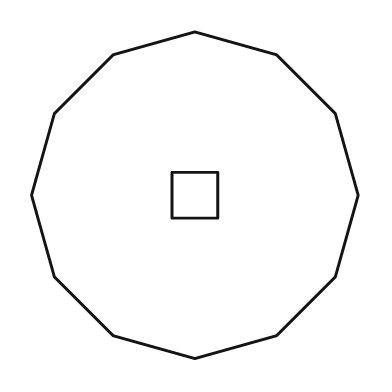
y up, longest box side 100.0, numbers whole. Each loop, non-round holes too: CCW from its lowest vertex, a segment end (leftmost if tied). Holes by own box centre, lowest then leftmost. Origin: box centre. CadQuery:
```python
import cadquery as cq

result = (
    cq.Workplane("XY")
    .moveTo(0.0, -50.0)
    .lineTo(25.0, -43.0)
    .lineTo(43.0, -25.0)
    .lineTo(50.0, 0.0)
    .lineTo(43.0, 25.0)
    .lineTo(25.0, 43.0)
    .lineTo(0.0, 50.0)
    .lineTo(-25.0, 43.0)
    .lineTo(-43.0, 25.0)
    .lineTo(-50.0, 0.0)
    .lineTo(-43.0, -25.0)
    .lineTo(-25.0, -43.0)
    .close()
    .moveTo(-7.0, -7.0)
    .lineTo(7.0, -7.0)
    .lineTo(7.0, 7.0)
    .lineTo(-7.0, 7.0)
    .close()
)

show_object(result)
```